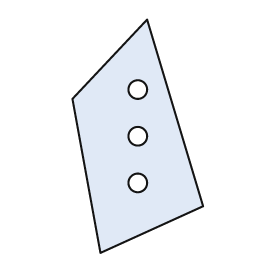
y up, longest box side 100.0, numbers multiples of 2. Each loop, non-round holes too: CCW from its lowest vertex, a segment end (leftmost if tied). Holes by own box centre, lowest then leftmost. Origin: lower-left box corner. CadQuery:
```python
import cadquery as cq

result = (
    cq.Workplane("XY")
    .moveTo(12.0, 0.0)
    .lineTo(56.0, 20.0)
    .lineTo(32.0, 100.0)
    .lineTo(0.0, 66.0)
    .close()
    .moveTo(28.0, 30.0)
    .circle(4.0)
    .moveTo(28.0, 50.0)
    .circle(4.0)
    .moveTo(28.0, 70.0)
    .circle(4.0)
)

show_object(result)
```